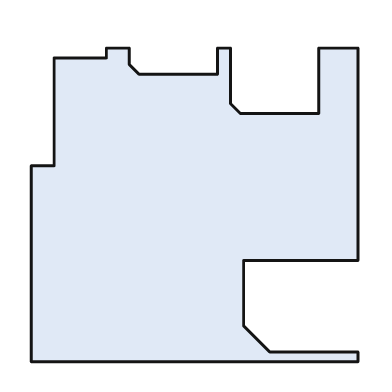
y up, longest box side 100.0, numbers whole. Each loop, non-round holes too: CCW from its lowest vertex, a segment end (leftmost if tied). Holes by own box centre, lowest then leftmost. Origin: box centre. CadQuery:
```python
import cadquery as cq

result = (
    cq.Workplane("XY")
    .moveTo(-50.0, -48.0)
    .lineTo(50.0, -48.0)
    .lineTo(50.0, -45.0)
    .lineTo(23.0, -45.0)
    .lineTo(15.0, -37.0)
    .lineTo(15.0, -17.0)
    .lineTo(50.0, -17.0)
    .lineTo(50.0, 48.0)
    .lineTo(38.0, 48.0)
    .lineTo(38.0, 28.0)
    .lineTo(14.0, 28.0)
    .lineTo(11.0, 31.0)
    .lineTo(11.0, 48.0)
    .lineTo(7.0, 48.0)
    .lineTo(7.0, 40.0)
    .lineTo(-17.0, 40.0)
    .lineTo(-20.0, 43.0)
    .lineTo(-20.0, 48.0)
    .lineTo(-27.0, 48.0)
    .lineTo(-27.0, 45.0)
    .lineTo(-43.0, 45.0)
    .lineTo(-43.0, 12.0)
    .lineTo(-50.0, 12.0)
    .close()
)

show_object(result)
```